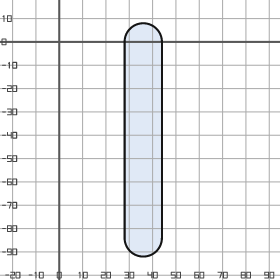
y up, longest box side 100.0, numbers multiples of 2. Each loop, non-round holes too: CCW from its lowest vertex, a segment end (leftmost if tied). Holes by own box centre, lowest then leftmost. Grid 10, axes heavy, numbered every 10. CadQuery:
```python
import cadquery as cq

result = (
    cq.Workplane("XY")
    .moveTo(28.0, -84.0)
    .threePointArc((36.0, -92.0), (44.0, -84.0))
    .lineTo(44.0, 0.0)
    .threePointArc((36.0, 8.0), (28.0, 0.0))
    .close()
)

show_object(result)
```